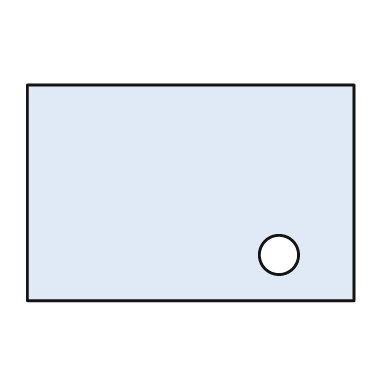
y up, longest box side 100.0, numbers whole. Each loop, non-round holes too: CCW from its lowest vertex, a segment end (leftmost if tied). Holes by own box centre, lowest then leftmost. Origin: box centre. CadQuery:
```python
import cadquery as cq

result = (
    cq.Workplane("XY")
    .moveTo(-50.0, -33.0)
    .lineTo(50.0, -33.0)
    .lineTo(50.0, 33.0)
    .lineTo(-50.0, 33.0)
    .close()
    .moveTo(27.0, -19.0)
    .circle(6.0)
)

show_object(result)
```